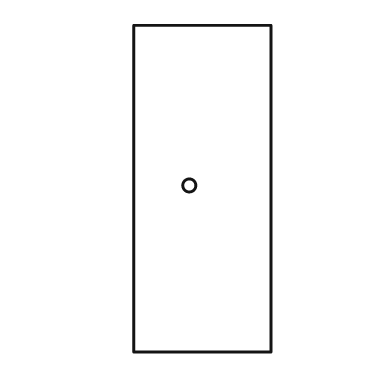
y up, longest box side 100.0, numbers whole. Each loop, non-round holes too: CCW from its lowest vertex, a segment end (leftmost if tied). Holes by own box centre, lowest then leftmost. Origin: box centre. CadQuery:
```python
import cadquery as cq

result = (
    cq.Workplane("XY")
    .moveTo(-21.0, -50.0)
    .lineTo(21.0, -50.0)
    .lineTo(21.0, 50.0)
    .lineTo(-21.0, 50.0)
    .close()
    .moveTo(-4.0, 1.0)
    .circle(2.0)
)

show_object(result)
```